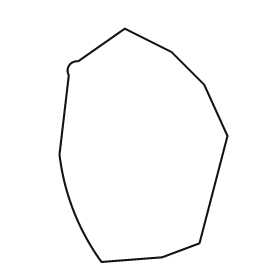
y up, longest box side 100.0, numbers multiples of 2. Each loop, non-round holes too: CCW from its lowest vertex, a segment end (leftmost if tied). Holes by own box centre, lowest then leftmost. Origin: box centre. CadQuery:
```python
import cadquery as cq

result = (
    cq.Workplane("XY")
    .moveTo(-18.0, -50.0)
    .lineTo(8.0, -48.0)
    .lineTo(24.0, -42.0)
    .lineTo(36.0, 4.0)
    .lineTo(26.0, 26.0)
    .lineTo(12.0, 40.0)
    .lineTo(-8.0, 50.0)
    .lineTo(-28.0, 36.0)
    .threePointArc((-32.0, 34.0), (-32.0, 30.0))
    .lineTo(-36.0, -4.0)
    .threePointArc((-30.0, -28.0), (-18.0, -50.0))
    .close()
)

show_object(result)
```